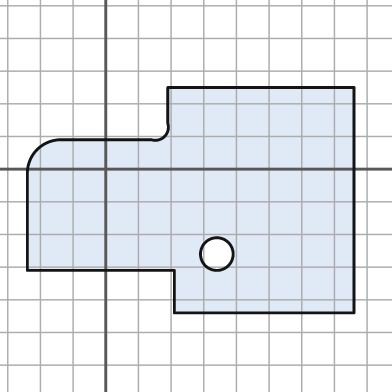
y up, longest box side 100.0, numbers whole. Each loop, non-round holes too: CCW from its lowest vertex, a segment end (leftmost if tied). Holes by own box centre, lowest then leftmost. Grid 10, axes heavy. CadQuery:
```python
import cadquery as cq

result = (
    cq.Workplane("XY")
    .moveTo(21.0, -44.0)
    .lineTo(76.0, -44.0)
    .lineTo(76.0, 25.0)
    .lineTo(19.0, 25.0)
    .lineTo(19.0, 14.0)
    .threePointArc((18.0, 10.0), (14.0, 9.0))
    .lineTo(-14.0, 9.0)
    .threePointArc((-21.0, 6.0), (-24.0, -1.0))
    .lineTo(-24.0, -31.0)
    .lineTo(21.0, -31.0)
    .close()
    .moveTo(34.0, -26.0)
    .circle(5.0)
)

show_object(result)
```